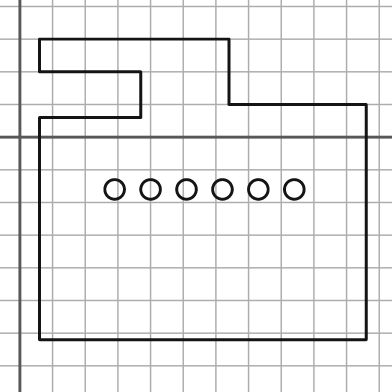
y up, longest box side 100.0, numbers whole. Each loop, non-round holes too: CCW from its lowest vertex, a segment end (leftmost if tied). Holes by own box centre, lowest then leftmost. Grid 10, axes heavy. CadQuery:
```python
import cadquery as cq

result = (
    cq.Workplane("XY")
    .moveTo(6.0, -62.0)
    .lineTo(106.0, -62.0)
    .lineTo(106.0, 10.0)
    .lineTo(64.0, 10.0)
    .lineTo(64.0, 30.0)
    .lineTo(6.0, 30.0)
    .lineTo(6.0, 20.0)
    .lineTo(37.0, 20.0)
    .lineTo(37.0, 6.0)
    .lineTo(6.0, 6.0)
    .close()
    .moveTo(29.0, -16.0)
    .circle(3.0)
    .moveTo(40.0, -16.0)
    .circle(3.0)
    .moveTo(51.0, -16.0)
    .circle(3.0)
    .moveTo(62.0, -16.0)
    .circle(3.0)
    .moveTo(73.0, -16.0)
    .circle(3.0)
    .moveTo(84.0, -16.0)
    .circle(3.0)
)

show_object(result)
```